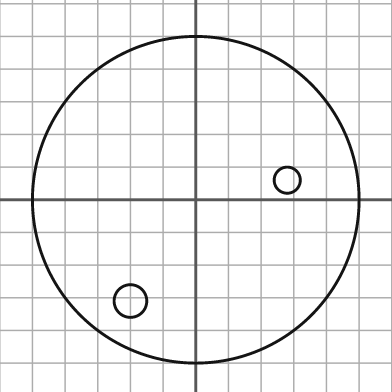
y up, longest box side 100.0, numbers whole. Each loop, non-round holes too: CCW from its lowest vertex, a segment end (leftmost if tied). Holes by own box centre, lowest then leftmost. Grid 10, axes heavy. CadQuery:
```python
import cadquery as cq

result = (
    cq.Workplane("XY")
    .moveTo(0.0, 0.0)
    .circle(50.0)
    .moveTo(-20.0, -31.0)
    .circle(5.0)
    .moveTo(28.0, 6.0)
    .circle(4.0)
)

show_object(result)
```